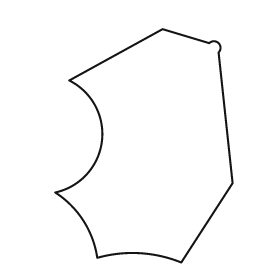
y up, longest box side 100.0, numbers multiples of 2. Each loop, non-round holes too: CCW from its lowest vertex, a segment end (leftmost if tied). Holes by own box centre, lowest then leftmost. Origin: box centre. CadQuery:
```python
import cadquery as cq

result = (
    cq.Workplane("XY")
    .moveTo(16.0, -50.0)
    .lineTo(38.0, -16.0)
    .lineTo(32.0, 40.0)
    .threePointArc((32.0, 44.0), (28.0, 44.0))
    .lineTo(8.0, 50.0)
    .lineTo(-32.0, 28.0)
    .threePointArc((-18.0, 2.0), (-38.0, -20.0))
    .threePointArc((-26.0, -32.0), (-20.0, -48.0))
    .threePointArc((-2.0, -46.0), (16.0, -50.0))
    .close()
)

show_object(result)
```